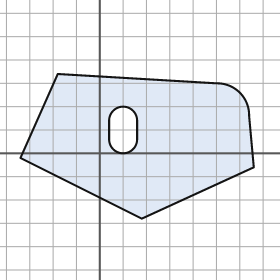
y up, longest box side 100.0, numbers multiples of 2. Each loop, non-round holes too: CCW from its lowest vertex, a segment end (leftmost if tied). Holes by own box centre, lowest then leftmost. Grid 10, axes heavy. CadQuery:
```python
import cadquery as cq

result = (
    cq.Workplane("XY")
    .moveTo(18.0, -28.0)
    .lineTo(66.0, -6.0)
    .lineTo(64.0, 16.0)
    .threePointArc((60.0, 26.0), (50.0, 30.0))
    .lineTo(-18.0, 34.0)
    .lineTo(-34.0, -2.0)
    .close()
    .moveTo(4.0, 6.0)
    .threePointArc((10.0, 0.0), (16.0, 6.0))
    .lineTo(16.0, 14.0)
    .threePointArc((10.0, 20.0), (4.0, 14.0))
    .close()
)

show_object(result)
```